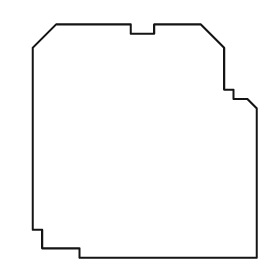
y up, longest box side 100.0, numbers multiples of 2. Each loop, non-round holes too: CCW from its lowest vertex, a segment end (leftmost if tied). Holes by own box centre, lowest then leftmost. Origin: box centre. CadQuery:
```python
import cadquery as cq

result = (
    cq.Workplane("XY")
    .moveTo(-28.0, -50.0)
    .lineTo(48.0, -50.0)
    .lineTo(48.0, 14.0)
    .lineTo(44.0, 18.0)
    .lineTo(38.0, 18.0)
    .lineTo(38.0, 22.0)
    .lineTo(34.0, 22.0)
    .lineTo(34.0, 40.0)
    .lineTo(24.0, 50.0)
    .lineTo(4.0, 50.0)
    .lineTo(4.0, 46.0)
    .lineTo(-6.0, 46.0)
    .lineTo(-6.0, 50.0)
    .lineTo(-38.0, 50.0)
    .lineTo(-48.0, 40.0)
    .lineTo(-48.0, -38.0)
    .lineTo(-44.0, -38.0)
    .lineTo(-44.0, -46.0)
    .lineTo(-28.0, -46.0)
    .close()
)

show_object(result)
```